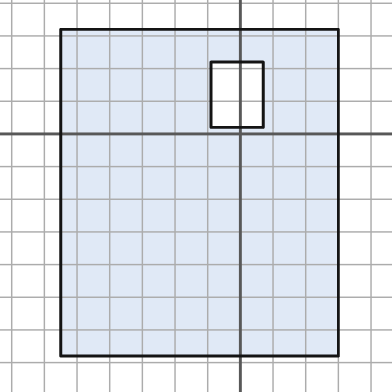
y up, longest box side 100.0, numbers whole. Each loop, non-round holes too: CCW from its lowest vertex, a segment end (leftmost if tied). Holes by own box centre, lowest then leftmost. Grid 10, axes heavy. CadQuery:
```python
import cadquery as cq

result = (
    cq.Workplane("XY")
    .moveTo(-55.0, -68.0)
    .lineTo(30.0, -68.0)
    .lineTo(30.0, 32.0)
    .lineTo(-55.0, 32.0)
    .close()
    .moveTo(-9.0, 2.0)
    .lineTo(7.0, 2.0)
    .lineTo(7.0, 22.0)
    .lineTo(-9.0, 22.0)
    .close()
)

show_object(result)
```